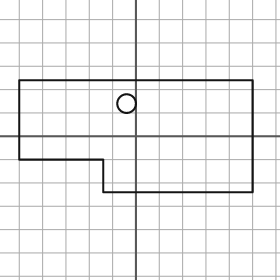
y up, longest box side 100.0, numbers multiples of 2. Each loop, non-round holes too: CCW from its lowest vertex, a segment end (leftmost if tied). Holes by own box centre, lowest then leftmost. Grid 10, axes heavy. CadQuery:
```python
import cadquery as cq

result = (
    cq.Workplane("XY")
    .moveTo(-14.0, -24.0)
    .lineTo(50.0, -24.0)
    .lineTo(50.0, 24.0)
    .lineTo(-50.0, 24.0)
    .lineTo(-50.0, -10.0)
    .lineTo(-14.0, -10.0)
    .close()
    .moveTo(-4.0, 14.0)
    .circle(4.0)
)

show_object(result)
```